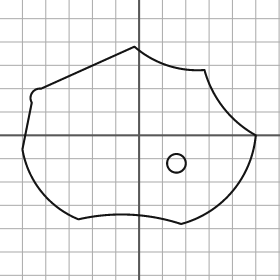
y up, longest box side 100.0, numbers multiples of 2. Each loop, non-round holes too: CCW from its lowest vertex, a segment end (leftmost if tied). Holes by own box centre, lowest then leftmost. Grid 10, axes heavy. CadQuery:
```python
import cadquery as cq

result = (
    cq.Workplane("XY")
    .moveTo(18.0, -38.0)
    .threePointArc((40.0, -24.0), (50.0, 0.0))
    .threePointArc((36.0, 12.0), (28.0, 28.0))
    .threePointArc((12.0, 30.0), (-2.0, 38.0))
    .lineTo(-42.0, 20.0)
    .threePointArc((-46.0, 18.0), (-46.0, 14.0))
    .lineTo(-50.0, -6.0)
    .threePointArc((-42.0, -24.0), (-26.0, -36.0))
    .threePointArc((-4.0, -34.0), (18.0, -38.0))
    .close()
    .moveTo(16.0, -12.0)
    .circle(4.0)
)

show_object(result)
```